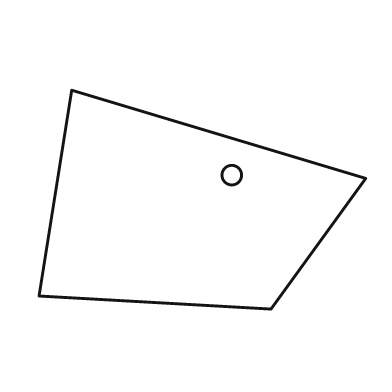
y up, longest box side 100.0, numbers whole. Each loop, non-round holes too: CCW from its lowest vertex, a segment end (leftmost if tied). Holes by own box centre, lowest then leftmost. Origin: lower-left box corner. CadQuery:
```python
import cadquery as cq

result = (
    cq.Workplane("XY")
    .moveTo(71.0, 0.0)
    .lineTo(100.0, 40.0)
    .lineTo(10.0, 67.0)
    .lineTo(0.0, 4.0)
    .close()
    .moveTo(59.0, 41.0)
    .circle(3.0)
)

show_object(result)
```